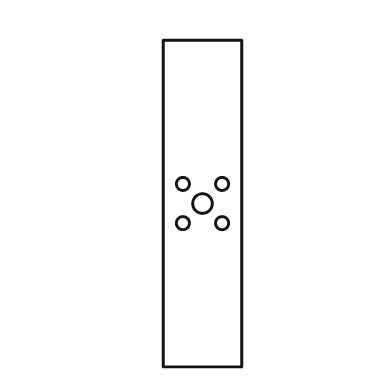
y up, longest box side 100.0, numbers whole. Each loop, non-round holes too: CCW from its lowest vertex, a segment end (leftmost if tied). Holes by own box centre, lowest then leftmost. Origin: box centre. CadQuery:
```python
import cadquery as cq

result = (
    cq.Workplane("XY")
    .moveTo(-12.0, -50.0)
    .lineTo(12.0, -50.0)
    .lineTo(12.0, 50.0)
    .lineTo(-12.0, 50.0)
    .close()
    .moveTo(-6.0, -6.0)
    .circle(2.0)
    .moveTo(6.0, -6.0)
    .circle(2.0)
    .moveTo(0.0, 0.0)
    .circle(3.0)
    .moveTo(-6.0, 6.0)
    .circle(2.0)
    .moveTo(6.0, 6.0)
    .circle(2.0)
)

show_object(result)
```